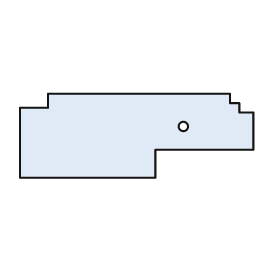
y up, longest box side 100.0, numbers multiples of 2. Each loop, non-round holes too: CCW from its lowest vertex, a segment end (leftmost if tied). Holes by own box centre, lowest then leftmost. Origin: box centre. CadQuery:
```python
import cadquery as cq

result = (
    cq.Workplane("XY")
    .moveTo(-50.0, -18.0)
    .lineTo(8.0, -18.0)
    .lineTo(8.0, -6.0)
    .lineTo(50.0, -6.0)
    .lineTo(50.0, 10.0)
    .lineTo(44.0, 10.0)
    .lineTo(44.0, 14.0)
    .lineTo(40.0, 14.0)
    .lineTo(40.0, 18.0)
    .lineTo(-38.0, 18.0)
    .lineTo(-38.0, 12.0)
    .lineTo(-50.0, 12.0)
    .close()
    .moveTo(20.0, 4.0)
    .circle(2.0)
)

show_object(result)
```